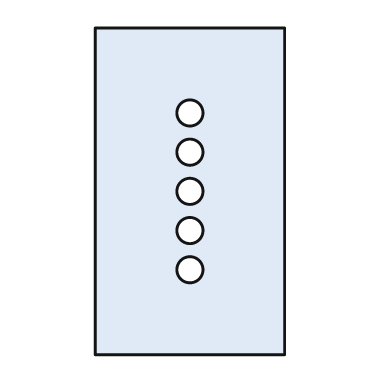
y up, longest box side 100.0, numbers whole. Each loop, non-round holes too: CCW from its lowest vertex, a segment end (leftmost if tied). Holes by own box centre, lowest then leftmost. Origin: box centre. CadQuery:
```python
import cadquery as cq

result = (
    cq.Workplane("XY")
    .moveTo(-29.0, -50.0)
    .lineTo(29.0, -50.0)
    .lineTo(29.0, 50.0)
    .lineTo(-29.0, 50.0)
    .close()
    .moveTo(0.0, -24.0)
    .circle(4.0)
    .moveTo(0.0, -12.0)
    .circle(4.0)
    .moveTo(0.0, 0.0)
    .circle(4.0)
    .moveTo(0.0, 12.0)
    .circle(4.0)
    .moveTo(0.0, 24.0)
    .circle(4.0)
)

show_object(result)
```